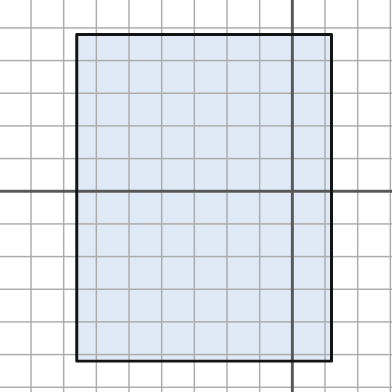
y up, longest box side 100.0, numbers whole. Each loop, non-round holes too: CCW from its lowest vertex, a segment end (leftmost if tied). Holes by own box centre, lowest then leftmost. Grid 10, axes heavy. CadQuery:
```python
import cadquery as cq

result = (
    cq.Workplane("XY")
    .moveTo(-66.0, -52.0)
    .lineTo(12.0, -52.0)
    .lineTo(12.0, 48.0)
    .lineTo(-66.0, 48.0)
    .close()
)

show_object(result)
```